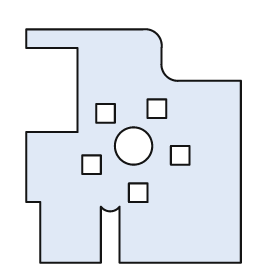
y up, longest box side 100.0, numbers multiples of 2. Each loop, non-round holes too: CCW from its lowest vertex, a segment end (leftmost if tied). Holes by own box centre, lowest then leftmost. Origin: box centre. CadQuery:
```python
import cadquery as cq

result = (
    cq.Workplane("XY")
    .moveTo(-40.0, -50.0)
    .lineTo(-14.0, -50.0)
    .lineTo(-14.0, -26.0)
    .threePointArc((-10.0, -28.0), (-6.0, -26.0))
    .lineTo(-6.0, -50.0)
    .lineTo(46.0, -50.0)
    .lineTo(46.0, 28.0)
    .lineTo(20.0, 28.0)
    .threePointArc((14.0, 30.0), (12.0, 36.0))
    .lineTo(12.0, 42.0)
    .threePointArc((10.0, 48.0), (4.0, 50.0))
    .lineTo(-46.0, 50.0)
    .lineTo(-46.0, 42.0)
    .lineTo(-24.0, 42.0)
    .lineTo(-24.0, 6.0)
    .lineTo(-46.0, 6.0)
    .lineTo(-46.0, -24.0)
    .lineTo(-40.0, -24.0)
    .close()
    .moveTo(-2.0, -24.0)
    .lineTo(6.0, -24.0)
    .lineTo(6.0, -16.0)
    .lineTo(-2.0, -16.0)
    .close()
    .moveTo(-22.0, -12.0)
    .lineTo(-14.0, -12.0)
    .lineTo(-14.0, -4.0)
    .lineTo(-22.0, -4.0)
    .close()
    .moveTo(16.0, -8.0)
    .lineTo(24.0, -8.0)
    .lineTo(24.0, 0.0)
    .lineTo(16.0, 0.0)
    .close()
    .moveTo(0.0, 0.0)
    .circle(8.0)
    .moveTo(-16.0, 10.0)
    .lineTo(-8.0, 10.0)
    .lineTo(-8.0, 18.0)
    .lineTo(-16.0, 18.0)
    .close()
    .moveTo(6.0, 12.0)
    .lineTo(14.0, 12.0)
    .lineTo(14.0, 20.0)
    .lineTo(6.0, 20.0)
    .close()
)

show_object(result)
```